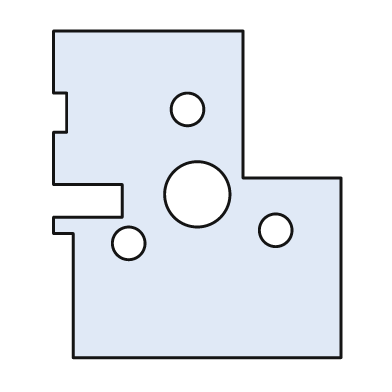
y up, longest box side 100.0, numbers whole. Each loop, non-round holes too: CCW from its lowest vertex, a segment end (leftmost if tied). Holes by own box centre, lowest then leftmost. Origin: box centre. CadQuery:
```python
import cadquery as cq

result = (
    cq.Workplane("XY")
    .moveTo(-38.0, -50.0)
    .lineTo(44.0, -50.0)
    .lineTo(44.0, 5.0)
    .lineTo(14.0, 5.0)
    .lineTo(14.0, 50.0)
    .lineTo(-44.0, 50.0)
    .lineTo(-44.0, 31.0)
    .lineTo(-40.0, 31.0)
    .lineTo(-40.0, 19.0)
    .lineTo(-44.0, 19.0)
    .lineTo(-44.0, 3.0)
    .lineTo(-23.0, 3.0)
    .lineTo(-23.0, -7.0)
    .lineTo(-44.0, -7.0)
    .lineTo(-44.0, -12.0)
    .lineTo(-38.0, -12.0)
    .close()
    .moveTo(-21.0, -15.0)
    .circle(5.0)
    .moveTo(24.0, -11.0)
    .circle(5.0)
    .moveTo(0.0, 0.0)
    .circle(10.0)
    .moveTo(-3.0, 26.0)
    .circle(5.0)
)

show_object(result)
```